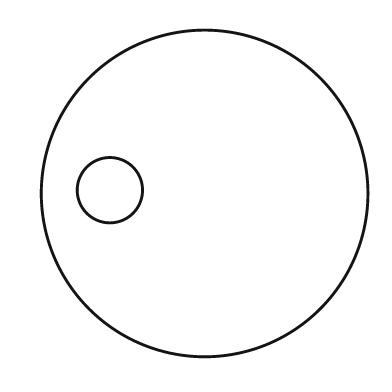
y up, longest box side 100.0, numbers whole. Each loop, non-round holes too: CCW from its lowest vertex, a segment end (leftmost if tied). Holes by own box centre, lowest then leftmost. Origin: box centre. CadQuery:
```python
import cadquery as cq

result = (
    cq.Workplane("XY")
    .moveTo(0.0, 0.0)
    .circle(50.0)
    .moveTo(-29.0, 1.0)
    .circle(10.0)
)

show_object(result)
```